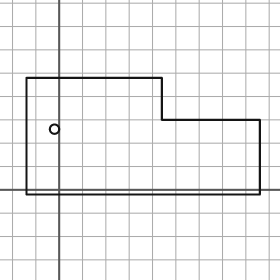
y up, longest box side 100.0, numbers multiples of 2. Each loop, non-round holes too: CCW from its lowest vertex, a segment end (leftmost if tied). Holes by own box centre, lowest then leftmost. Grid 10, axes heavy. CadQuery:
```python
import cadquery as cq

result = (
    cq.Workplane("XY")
    .moveTo(-14.0, -2.0)
    .lineTo(86.0, -2.0)
    .lineTo(86.0, 30.0)
    .lineTo(44.0, 30.0)
    .lineTo(44.0, 48.0)
    .lineTo(-14.0, 48.0)
    .close()
    .moveTo(-2.0, 26.0)
    .circle(2.0)
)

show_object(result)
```